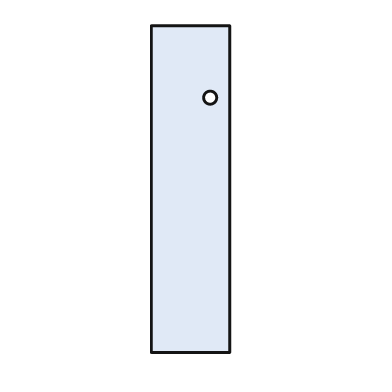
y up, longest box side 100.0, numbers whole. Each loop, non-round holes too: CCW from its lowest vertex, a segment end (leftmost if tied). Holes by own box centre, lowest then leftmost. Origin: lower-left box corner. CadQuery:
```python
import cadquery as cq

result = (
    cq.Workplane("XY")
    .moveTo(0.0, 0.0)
    .lineTo(24.0, 0.0)
    .lineTo(24.0, 100.0)
    .lineTo(0.0, 100.0)
    .close()
    .moveTo(18.0, 78.0)
    .circle(2.0)
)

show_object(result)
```